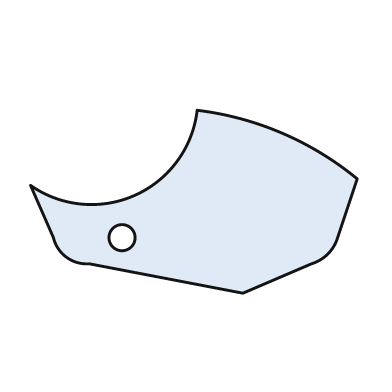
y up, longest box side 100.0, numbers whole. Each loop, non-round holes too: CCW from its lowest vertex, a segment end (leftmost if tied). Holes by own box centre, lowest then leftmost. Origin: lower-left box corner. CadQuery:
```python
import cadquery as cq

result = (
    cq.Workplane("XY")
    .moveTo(65.0, 0.0)
    .lineTo(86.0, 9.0)
    .threePointArc((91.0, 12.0), (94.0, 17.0))
    .lineTo(100.0, 35.0)
    .threePointArc((77.0, 49.0), (51.0, 56.0))
    .threePointArc((32.0, 30.0), (0.0, 33.0))
    .lineTo(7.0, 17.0)
    .threePointArc((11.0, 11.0), (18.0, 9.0))
    .close()
    .moveTo(28.0, 17.0)
    .circle(4.0)
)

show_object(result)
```